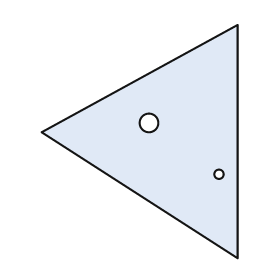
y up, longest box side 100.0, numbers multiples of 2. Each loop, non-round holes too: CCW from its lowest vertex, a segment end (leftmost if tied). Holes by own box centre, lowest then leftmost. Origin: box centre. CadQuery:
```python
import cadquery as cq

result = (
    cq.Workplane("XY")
    .moveTo(42.0, -50.0)
    .lineTo(42.0, 50.0)
    .lineTo(-42.0, 4.0)
    .close()
    .moveTo(34.0, -14.0)
    .circle(2.0)
    .moveTo(4.0, 8.0)
    .circle(4.0)
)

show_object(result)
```